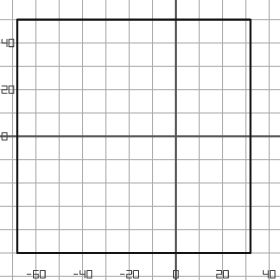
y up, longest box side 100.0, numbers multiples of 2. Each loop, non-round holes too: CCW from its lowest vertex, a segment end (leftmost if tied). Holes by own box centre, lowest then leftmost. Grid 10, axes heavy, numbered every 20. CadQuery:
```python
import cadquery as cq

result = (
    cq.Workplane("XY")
    .moveTo(-68.0, -50.0)
    .lineTo(32.0, -50.0)
    .lineTo(32.0, 50.0)
    .lineTo(-68.0, 50.0)
    .close()
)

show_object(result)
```